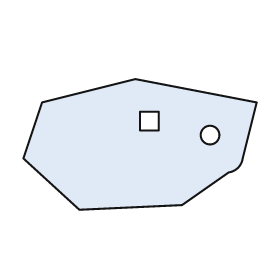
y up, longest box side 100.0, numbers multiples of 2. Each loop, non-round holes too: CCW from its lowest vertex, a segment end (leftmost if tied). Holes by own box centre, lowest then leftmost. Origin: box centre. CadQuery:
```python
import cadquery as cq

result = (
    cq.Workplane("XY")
    .moveTo(-26.0, -28.0)
    .lineTo(18.0, -26.0)
    .lineTo(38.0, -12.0)
    .threePointArc((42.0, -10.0), (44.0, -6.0))
    .lineTo(50.0, 18.0)
    .lineTo(-2.0, 28.0)
    .lineTo(-42.0, 18.0)
    .lineTo(-50.0, -6.0)
    .close()
    .moveTo(30.0, 4.0)
    .circle(4.0)
    .moveTo(0.0, 6.0)
    .lineTo(8.0, 6.0)
    .lineTo(8.0, 14.0)
    .lineTo(0.0, 14.0)
    .close()
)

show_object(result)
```